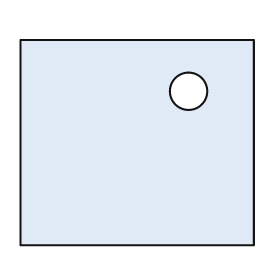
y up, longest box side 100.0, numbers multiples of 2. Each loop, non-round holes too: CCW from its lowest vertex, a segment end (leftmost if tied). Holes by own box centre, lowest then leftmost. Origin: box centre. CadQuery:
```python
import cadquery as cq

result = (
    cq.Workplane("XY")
    .moveTo(-50.0, -44.0)
    .lineTo(50.0, -44.0)
    .lineTo(50.0, 44.0)
    .lineTo(-50.0, 44.0)
    .close()
    .moveTo(22.0, 22.0)
    .circle(8.0)
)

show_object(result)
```